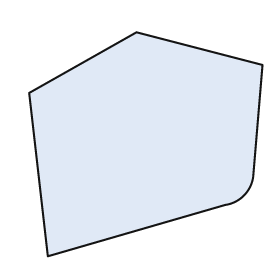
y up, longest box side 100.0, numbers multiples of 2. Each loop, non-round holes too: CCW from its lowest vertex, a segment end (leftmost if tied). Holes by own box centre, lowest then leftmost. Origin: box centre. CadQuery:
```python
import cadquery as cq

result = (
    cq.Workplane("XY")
    .moveTo(-42.0, -48.0)
    .lineTo(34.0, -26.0)
    .threePointArc((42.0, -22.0), (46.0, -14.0))
    .lineTo(50.0, 34.0)
    .lineTo(-4.0, 48.0)
    .lineTo(-50.0, 22.0)
    .close()
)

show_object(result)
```